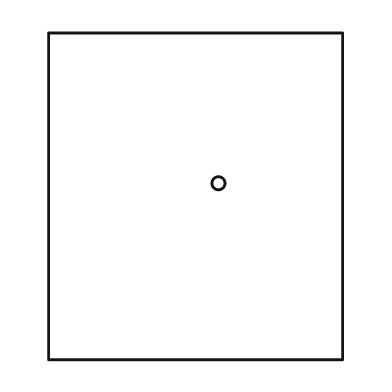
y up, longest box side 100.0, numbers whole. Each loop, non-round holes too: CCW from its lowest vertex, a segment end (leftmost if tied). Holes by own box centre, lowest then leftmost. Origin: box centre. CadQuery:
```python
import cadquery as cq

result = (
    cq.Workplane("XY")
    .moveTo(-45.0, -50.0)
    .lineTo(45.0, -50.0)
    .lineTo(45.0, 50.0)
    .lineTo(-45.0, 50.0)
    .close()
    .moveTo(7.0, 4.0)
    .circle(2.0)
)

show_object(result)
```